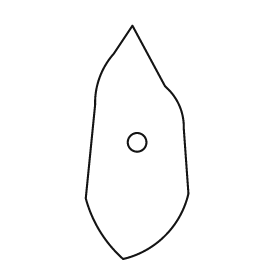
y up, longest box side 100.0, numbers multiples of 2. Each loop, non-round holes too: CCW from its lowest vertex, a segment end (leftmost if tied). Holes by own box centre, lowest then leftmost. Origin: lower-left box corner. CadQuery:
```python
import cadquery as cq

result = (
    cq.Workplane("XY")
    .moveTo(16.0, 0.0)
    .threePointArc((34.0, 10.0), (44.0, 28.0))
    .lineTo(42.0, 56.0)
    .threePointArc((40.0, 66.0), (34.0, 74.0))
    .lineTo(20.0, 100.0)
    .lineTo(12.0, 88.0)
    .threePointArc((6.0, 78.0), (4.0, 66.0))
    .lineTo(0.0, 26.0)
    .threePointArc((6.0, 12.0), (16.0, 0.0))
    .close()
    .moveTo(22.0, 50.0)
    .circle(4.0)
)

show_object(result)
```